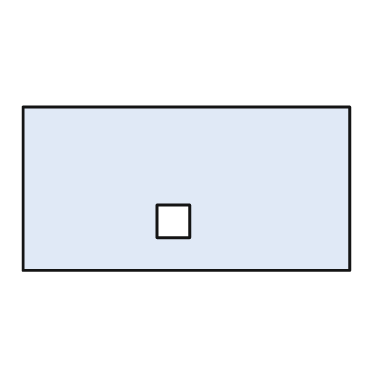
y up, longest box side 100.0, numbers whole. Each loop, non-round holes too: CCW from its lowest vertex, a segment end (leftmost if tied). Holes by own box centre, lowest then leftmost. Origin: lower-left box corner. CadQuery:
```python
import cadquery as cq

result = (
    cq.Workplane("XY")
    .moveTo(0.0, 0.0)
    .lineTo(100.0, 0.0)
    .lineTo(100.0, 50.0)
    .lineTo(0.0, 50.0)
    .close()
    .moveTo(41.0, 10.0)
    .lineTo(51.0, 10.0)
    .lineTo(51.0, 20.0)
    .lineTo(41.0, 20.0)
    .close()
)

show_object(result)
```